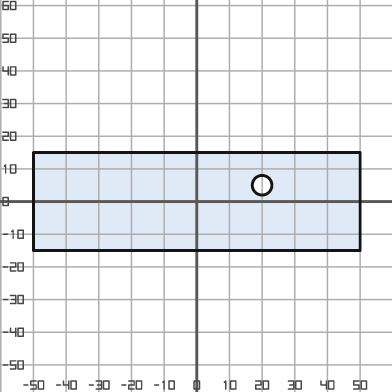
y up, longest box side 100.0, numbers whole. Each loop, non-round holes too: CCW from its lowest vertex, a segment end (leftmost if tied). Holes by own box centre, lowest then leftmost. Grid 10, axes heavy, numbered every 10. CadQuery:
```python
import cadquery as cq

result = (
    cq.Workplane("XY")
    .moveTo(-50.0, -15.0)
    .lineTo(50.0, -15.0)
    .lineTo(50.0, 15.0)
    .lineTo(-50.0, 15.0)
    .close()
    .moveTo(20.0, 5.0)
    .circle(3.0)
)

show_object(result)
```